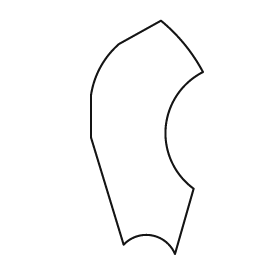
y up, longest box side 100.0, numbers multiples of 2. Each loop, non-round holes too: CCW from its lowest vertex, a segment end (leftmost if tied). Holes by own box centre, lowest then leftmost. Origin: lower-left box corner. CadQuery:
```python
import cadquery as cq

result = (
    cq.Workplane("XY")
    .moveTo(36.0, 0.0)
    .lineTo(44.0, 28.0)
    .threePointArc((32.0, 54.0), (48.0, 78.0))
    .threePointArc((40.0, 90.0), (30.0, 100.0))
    .lineTo(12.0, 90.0)
    .threePointArc((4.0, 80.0), (0.0, 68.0))
    .lineTo(0.0, 50.0)
    .lineTo(14.0, 4.0)
    .threePointArc((26.0, 8.0), (36.0, 0.0))
    .close()
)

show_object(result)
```